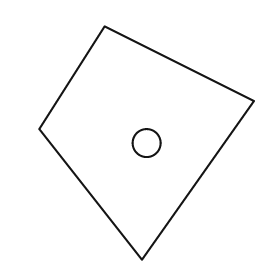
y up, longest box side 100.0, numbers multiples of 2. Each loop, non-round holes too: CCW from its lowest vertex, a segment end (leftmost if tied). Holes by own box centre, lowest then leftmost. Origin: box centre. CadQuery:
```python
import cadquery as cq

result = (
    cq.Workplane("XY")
    .moveTo(-2.0, -50.0)
    .lineTo(46.0, 18.0)
    .lineTo(-18.0, 50.0)
    .lineTo(-46.0, 6.0)
    .close()
    .moveTo(0.0, 0.0)
    .circle(6.0)
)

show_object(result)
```